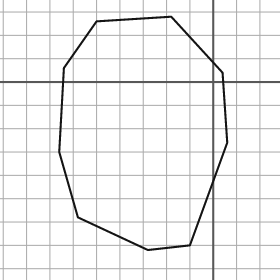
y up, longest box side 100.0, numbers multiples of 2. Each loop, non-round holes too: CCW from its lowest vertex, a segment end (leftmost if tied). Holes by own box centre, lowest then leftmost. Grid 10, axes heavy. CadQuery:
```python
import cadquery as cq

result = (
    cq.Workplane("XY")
    .moveTo(-28.0, -72.0)
    .lineTo(-10.0, -70.0)
    .lineTo(6.0, -26.0)
    .lineTo(4.0, 4.0)
    .lineTo(-18.0, 28.0)
    .lineTo(-50.0, 26.0)
    .lineTo(-64.0, 6.0)
    .lineTo(-66.0, -30.0)
    .lineTo(-58.0, -58.0)
    .close()
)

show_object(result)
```